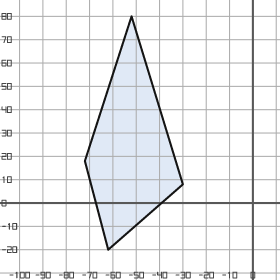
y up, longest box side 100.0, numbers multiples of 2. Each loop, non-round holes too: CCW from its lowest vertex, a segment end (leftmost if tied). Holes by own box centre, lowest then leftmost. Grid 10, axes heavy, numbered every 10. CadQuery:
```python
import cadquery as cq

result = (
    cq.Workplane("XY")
    .moveTo(-62.0, -20.0)
    .lineTo(-30.0, 8.0)
    .lineTo(-52.0, 80.0)
    .lineTo(-72.0, 18.0)
    .close()
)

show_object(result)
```